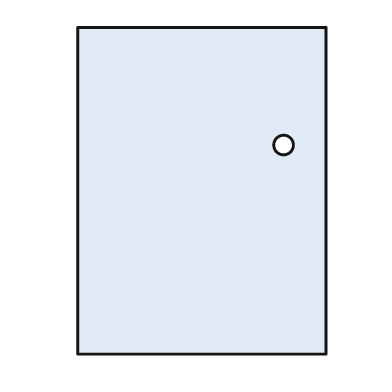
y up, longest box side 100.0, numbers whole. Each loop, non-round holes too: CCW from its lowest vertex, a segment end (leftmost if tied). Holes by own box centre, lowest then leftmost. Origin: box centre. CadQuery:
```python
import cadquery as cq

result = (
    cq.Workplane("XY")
    .moveTo(-38.0, -50.0)
    .lineTo(38.0, -50.0)
    .lineTo(38.0, 50.0)
    .lineTo(-38.0, 50.0)
    .close()
    .moveTo(25.0, 14.0)
    .circle(3.0)
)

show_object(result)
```